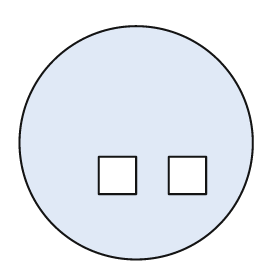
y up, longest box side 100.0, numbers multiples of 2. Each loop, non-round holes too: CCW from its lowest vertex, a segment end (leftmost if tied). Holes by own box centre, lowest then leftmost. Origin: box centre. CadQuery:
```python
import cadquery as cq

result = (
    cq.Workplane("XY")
    .moveTo(0.0, 0.0)
    .circle(50.0)
    .moveTo(-16.0, -22.0)
    .lineTo(0.0, -22.0)
    .lineTo(0.0, -6.0)
    .lineTo(-16.0, -6.0)
    .close()
    .moveTo(14.0, -22.0)
    .lineTo(30.0, -22.0)
    .lineTo(30.0, -6.0)
    .lineTo(14.0, -6.0)
    .close()
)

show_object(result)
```